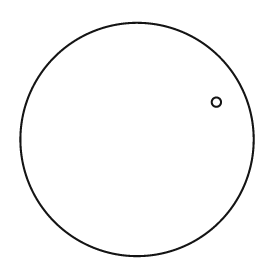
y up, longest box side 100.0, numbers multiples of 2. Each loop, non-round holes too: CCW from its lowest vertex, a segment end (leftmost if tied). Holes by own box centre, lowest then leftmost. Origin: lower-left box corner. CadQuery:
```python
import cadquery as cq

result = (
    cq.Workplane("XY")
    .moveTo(50.0, 50.0)
    .circle(50.0)
    .moveTo(84.0, 66.0)
    .circle(2.0)
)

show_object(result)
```